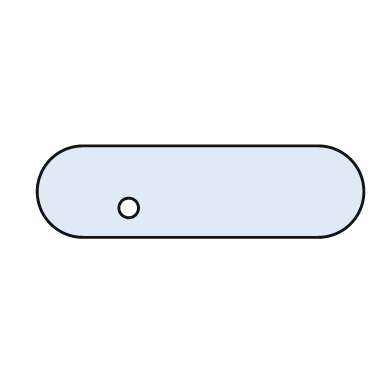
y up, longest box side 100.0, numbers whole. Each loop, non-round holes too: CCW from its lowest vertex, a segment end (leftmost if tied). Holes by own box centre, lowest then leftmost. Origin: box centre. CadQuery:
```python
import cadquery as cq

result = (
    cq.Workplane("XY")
    .moveTo(-36.0, -14.0)
    .lineTo(36.0, -14.0)
    .threePointArc((50.0, 0.0), (36.0, 14.0))
    .lineTo(-36.0, 14.0)
    .threePointArc((-50.0, 0.0), (-36.0, -14.0))
    .close()
    .moveTo(-22.0, -5.0)
    .circle(3.0)
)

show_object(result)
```